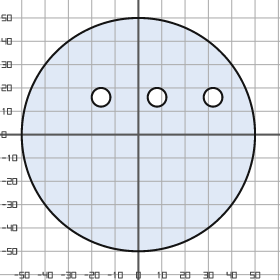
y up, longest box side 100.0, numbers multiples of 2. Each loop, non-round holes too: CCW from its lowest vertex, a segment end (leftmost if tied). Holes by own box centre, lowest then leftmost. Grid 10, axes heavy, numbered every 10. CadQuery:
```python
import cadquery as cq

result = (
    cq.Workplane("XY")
    .moveTo(0.0, 0.0)
    .circle(50.0)
    .moveTo(-16.0, 16.0)
    .circle(4.0)
    .moveTo(8.0, 16.0)
    .circle(4.0)
    .moveTo(32.0, 16.0)
    .circle(4.0)
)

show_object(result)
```